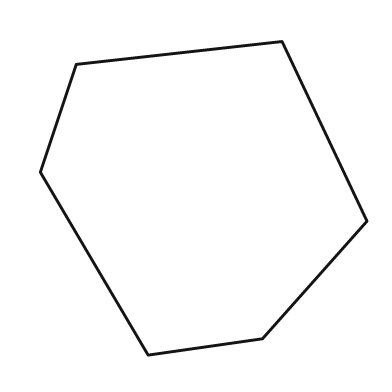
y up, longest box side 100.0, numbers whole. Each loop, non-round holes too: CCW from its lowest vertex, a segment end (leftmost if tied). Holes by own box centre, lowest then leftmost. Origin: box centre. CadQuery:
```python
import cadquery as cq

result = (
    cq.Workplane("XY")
    .moveTo(-17.0, -48.0)
    .lineTo(18.0, -43.0)
    .lineTo(50.0, -7.0)
    .lineTo(24.0, 48.0)
    .lineTo(-39.0, 41.0)
    .lineTo(-50.0, 8.0)
    .close()
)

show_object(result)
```